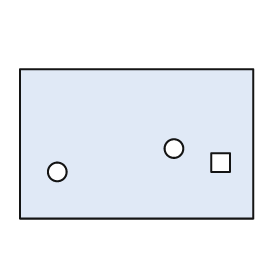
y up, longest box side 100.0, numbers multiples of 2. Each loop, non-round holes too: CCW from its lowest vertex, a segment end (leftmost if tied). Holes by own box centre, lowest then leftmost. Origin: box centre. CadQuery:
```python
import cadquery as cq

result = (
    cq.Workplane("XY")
    .moveTo(-50.0, -32.0)
    .lineTo(50.0, -32.0)
    .lineTo(50.0, 32.0)
    .lineTo(-50.0, 32.0)
    .close()
    .moveTo(-34.0, -12.0)
    .circle(4.0)
    .moveTo(32.0, -12.0)
    .lineTo(40.0, -12.0)
    .lineTo(40.0, -4.0)
    .lineTo(32.0, -4.0)
    .close()
    .moveTo(16.0, -2.0)
    .circle(4.0)
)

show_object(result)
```